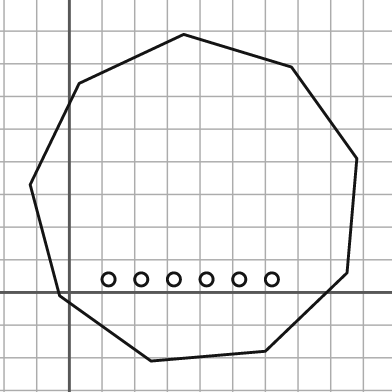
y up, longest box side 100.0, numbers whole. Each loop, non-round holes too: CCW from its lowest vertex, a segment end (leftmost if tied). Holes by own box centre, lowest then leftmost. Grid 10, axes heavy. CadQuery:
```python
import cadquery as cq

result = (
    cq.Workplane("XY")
    .moveTo(25.0, -21.0)
    .lineTo(60.0, -18.0)
    .lineTo(85.0, 6.0)
    .lineTo(88.0, 41.0)
    .lineTo(68.0, 69.0)
    .lineTo(35.0, 79.0)
    .lineTo(3.0, 64.0)
    .lineTo(-12.0, 33.0)
    .lineTo(-3.0, -1.0)
    .close()
    .moveTo(12.0, 4.0)
    .circle(2.0)
    .moveTo(22.0, 4.0)
    .circle(2.0)
    .moveTo(32.0, 4.0)
    .circle(2.0)
    .moveTo(42.0, 4.0)
    .circle(2.0)
    .moveTo(52.0, 4.0)
    .circle(2.0)
    .moveTo(62.0, 4.0)
    .circle(2.0)
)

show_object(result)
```